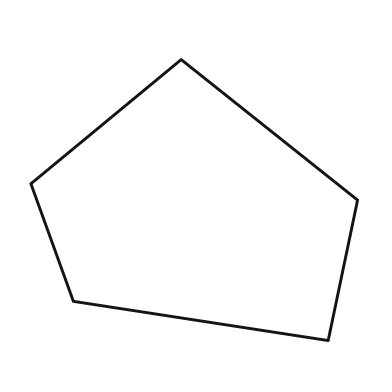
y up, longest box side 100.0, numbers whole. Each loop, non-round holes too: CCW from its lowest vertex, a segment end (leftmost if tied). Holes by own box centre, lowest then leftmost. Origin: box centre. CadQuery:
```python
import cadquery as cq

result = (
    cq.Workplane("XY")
    .moveTo(41.0, -43.0)
    .lineTo(50.0, 0.0)
    .lineTo(-4.0, 43.0)
    .lineTo(-50.0, 5.0)
    .lineTo(-37.0, -31.0)
    .close()
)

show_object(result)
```